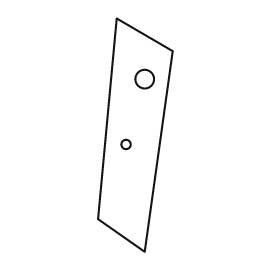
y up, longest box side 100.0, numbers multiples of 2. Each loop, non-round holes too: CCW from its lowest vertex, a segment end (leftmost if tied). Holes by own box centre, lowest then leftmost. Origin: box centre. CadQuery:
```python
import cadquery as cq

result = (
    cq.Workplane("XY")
    .moveTo(4.0, -50.0)
    .lineTo(16.0, 36.0)
    .lineTo(-8.0, 50.0)
    .lineTo(-16.0, -36.0)
    .close()
    .moveTo(-4.0, -4.0)
    .circle(2.0)
    .moveTo(4.0, 24.0)
    .circle(4.0)
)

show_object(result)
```